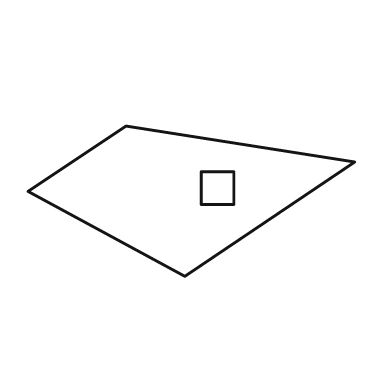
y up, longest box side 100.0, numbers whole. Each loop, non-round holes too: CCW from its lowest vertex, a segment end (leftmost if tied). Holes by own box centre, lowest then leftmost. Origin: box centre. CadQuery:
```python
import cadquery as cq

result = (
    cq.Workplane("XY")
    .moveTo(-2.0, -23.0)
    .lineTo(50.0, 12.0)
    .lineTo(-20.0, 23.0)
    .lineTo(-50.0, 3.0)
    .close()
    .moveTo(3.0, -1.0)
    .lineTo(13.0, -1.0)
    .lineTo(13.0, 9.0)
    .lineTo(3.0, 9.0)
    .close()
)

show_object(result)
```